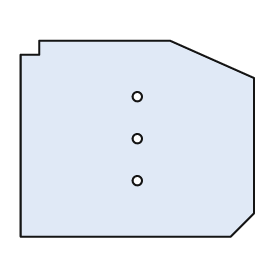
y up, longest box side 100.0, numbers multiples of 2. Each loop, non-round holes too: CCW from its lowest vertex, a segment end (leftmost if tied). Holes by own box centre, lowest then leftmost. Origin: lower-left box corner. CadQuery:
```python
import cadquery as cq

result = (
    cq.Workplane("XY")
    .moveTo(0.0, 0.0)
    .lineTo(90.0, 0.0)
    .lineTo(100.0, 10.0)
    .lineTo(100.0, 68.0)
    .lineTo(64.0, 84.0)
    .lineTo(8.0, 84.0)
    .lineTo(8.0, 78.0)
    .lineTo(0.0, 78.0)
    .close()
    .moveTo(50.0, 24.0)
    .circle(2.0)
    .moveTo(50.0, 42.0)
    .circle(2.0)
    .moveTo(50.0, 60.0)
    .circle(2.0)
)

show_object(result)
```